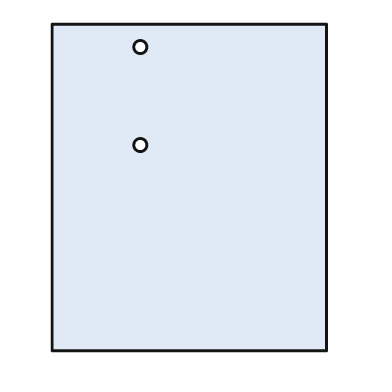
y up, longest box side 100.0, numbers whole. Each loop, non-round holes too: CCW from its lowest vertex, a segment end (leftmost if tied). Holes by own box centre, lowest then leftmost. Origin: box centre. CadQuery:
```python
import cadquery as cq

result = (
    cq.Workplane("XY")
    .moveTo(-42.0, -50.0)
    .lineTo(42.0, -50.0)
    .lineTo(42.0, 50.0)
    .lineTo(-42.0, 50.0)
    .close()
    .moveTo(-15.0, 13.0)
    .circle(2.0)
    .moveTo(-15.0, 43.0)
    .circle(2.0)
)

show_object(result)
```